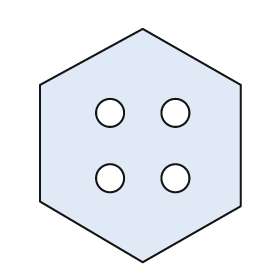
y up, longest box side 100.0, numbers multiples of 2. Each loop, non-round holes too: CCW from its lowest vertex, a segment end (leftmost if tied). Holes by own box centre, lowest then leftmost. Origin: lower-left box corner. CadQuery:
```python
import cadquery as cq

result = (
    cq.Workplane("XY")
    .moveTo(44.0, 0.0)
    .lineTo(86.0, 24.0)
    .lineTo(86.0, 76.0)
    .lineTo(44.0, 100.0)
    .lineTo(0.0, 76.0)
    .lineTo(0.0, 26.0)
    .close()
    .moveTo(30.0, 36.0)
    .circle(6.0)
    .moveTo(58.0, 36.0)
    .circle(6.0)
    .moveTo(30.0, 64.0)
    .circle(6.0)
    .moveTo(58.0, 64.0)
    .circle(6.0)
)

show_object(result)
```